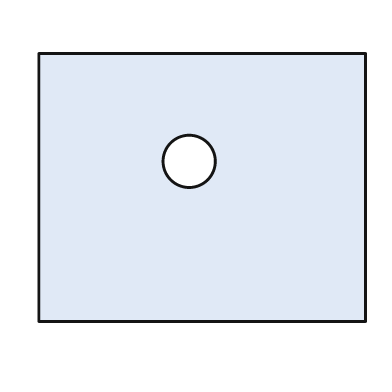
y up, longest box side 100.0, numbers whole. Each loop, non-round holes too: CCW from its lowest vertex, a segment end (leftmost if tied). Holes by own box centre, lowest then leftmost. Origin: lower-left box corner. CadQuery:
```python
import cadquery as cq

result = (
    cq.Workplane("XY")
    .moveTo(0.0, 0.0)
    .lineTo(100.0, 0.0)
    .lineTo(100.0, 82.0)
    .lineTo(0.0, 82.0)
    .close()
    .moveTo(46.0, 49.0)
    .circle(8.0)
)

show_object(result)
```